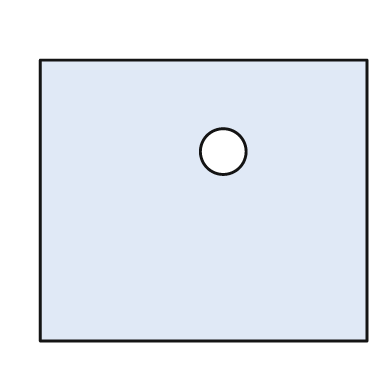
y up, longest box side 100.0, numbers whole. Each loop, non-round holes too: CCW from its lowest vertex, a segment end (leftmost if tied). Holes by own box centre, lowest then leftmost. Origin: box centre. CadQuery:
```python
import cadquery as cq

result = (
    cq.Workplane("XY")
    .moveTo(-50.0, -43.0)
    .lineTo(50.0, -43.0)
    .lineTo(50.0, 43.0)
    .lineTo(-50.0, 43.0)
    .close()
    .moveTo(6.0, 15.0)
    .circle(7.0)
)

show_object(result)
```